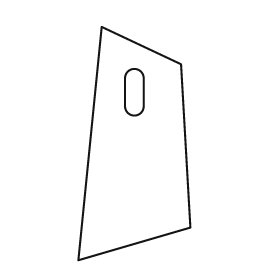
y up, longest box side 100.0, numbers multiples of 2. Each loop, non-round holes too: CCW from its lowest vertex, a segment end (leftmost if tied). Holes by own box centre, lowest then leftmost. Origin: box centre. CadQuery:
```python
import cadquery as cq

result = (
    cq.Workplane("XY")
    .moveTo(-24.0, -50.0)
    .lineTo(24.0, -36.0)
    .lineTo(20.0, 34.0)
    .lineTo(-14.0, 50.0)
    .close()
    .moveTo(-4.0, 16.0)
    .threePointArc((0.0, 12.0), (4.0, 16.0))
    .lineTo(4.0, 28.0)
    .threePointArc((0.0, 32.0), (-4.0, 28.0))
    .close()
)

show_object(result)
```